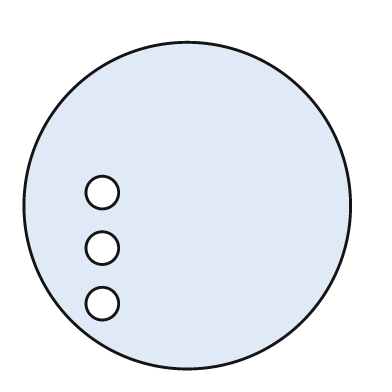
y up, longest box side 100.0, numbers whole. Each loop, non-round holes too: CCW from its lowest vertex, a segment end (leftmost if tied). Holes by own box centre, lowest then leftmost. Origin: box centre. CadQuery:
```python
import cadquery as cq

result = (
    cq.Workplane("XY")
    .moveTo(0.0, 0.0)
    .circle(50.0)
    .moveTo(-26.0, -30.0)
    .circle(5.0)
    .moveTo(-26.0, -13.0)
    .circle(5.0)
    .moveTo(-26.0, 4.0)
    .circle(5.0)
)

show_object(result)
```